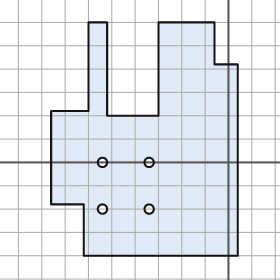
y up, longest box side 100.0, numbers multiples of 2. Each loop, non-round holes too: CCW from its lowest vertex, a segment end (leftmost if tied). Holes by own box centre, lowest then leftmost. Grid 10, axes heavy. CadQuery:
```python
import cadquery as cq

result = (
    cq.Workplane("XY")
    .moveTo(-62.0, -40.0)
    .lineTo(4.0, -40.0)
    .lineTo(4.0, 42.0)
    .lineTo(-6.0, 42.0)
    .lineTo(-6.0, 60.0)
    .lineTo(-30.0, 60.0)
    .lineTo(-30.0, 20.0)
    .lineTo(-52.0, 20.0)
    .lineTo(-52.0, 60.0)
    .lineTo(-60.0, 60.0)
    .lineTo(-60.0, 22.0)
    .lineTo(-76.0, 22.0)
    .lineTo(-76.0, -18.0)
    .lineTo(-62.0, -18.0)
    .close()
    .moveTo(-54.0, -20.0)
    .circle(2.0)
    .moveTo(-34.0, -20.0)
    .circle(2.0)
    .moveTo(-54.0, 0.0)
    .circle(2.0)
    .moveTo(-34.0, 0.0)
    .circle(2.0)
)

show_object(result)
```